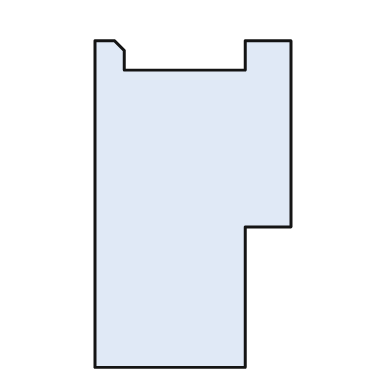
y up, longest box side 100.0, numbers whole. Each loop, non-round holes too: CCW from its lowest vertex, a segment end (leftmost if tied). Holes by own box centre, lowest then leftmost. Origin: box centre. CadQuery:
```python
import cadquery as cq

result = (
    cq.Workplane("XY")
    .moveTo(-30.0, -50.0)
    .lineTo(16.0, -50.0)
    .lineTo(16.0, -7.0)
    .lineTo(30.0, -7.0)
    .lineTo(30.0, 50.0)
    .lineTo(16.0, 50.0)
    .lineTo(16.0, 41.0)
    .lineTo(-21.0, 41.0)
    .lineTo(-21.0, 47.0)
    .lineTo(-24.0, 50.0)
    .lineTo(-30.0, 50.0)
    .close()
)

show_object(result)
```